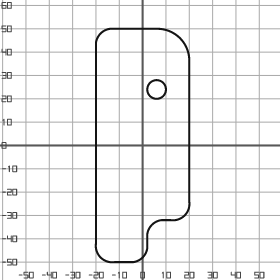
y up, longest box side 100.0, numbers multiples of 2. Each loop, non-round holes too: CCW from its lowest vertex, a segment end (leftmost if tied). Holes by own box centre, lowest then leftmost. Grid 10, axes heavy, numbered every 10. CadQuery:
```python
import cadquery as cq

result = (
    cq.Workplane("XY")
    .moveTo(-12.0, -50.0)
    .lineTo(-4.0, -50.0)
    .threePointArc((0.0, -48.0), (2.0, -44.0))
    .lineTo(2.0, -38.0)
    .threePointArc((4.0, -34.0), (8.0, -32.0))
    .lineTo(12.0, -32.0)
    .threePointArc((18.0, -30.0), (20.0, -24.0))
    .lineTo(20.0, 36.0)
    .threePointArc((16.0, 46.0), (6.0, 50.0))
    .lineTo(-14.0, 50.0)
    .threePointArc((-18.0, 48.0), (-20.0, 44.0))
    .lineTo(-20.0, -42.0)
    .threePointArc((-18.0, -48.0), (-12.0, -50.0))
    .close()
    .moveTo(6.0, 24.0)
    .circle(4.0)
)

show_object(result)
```